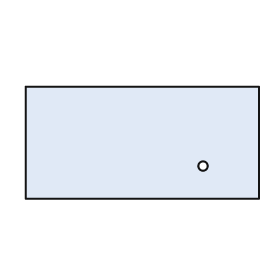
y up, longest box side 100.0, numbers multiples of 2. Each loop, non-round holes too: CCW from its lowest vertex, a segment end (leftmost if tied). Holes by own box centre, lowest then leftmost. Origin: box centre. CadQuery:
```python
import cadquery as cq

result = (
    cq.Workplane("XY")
    .moveTo(-50.0, -24.0)
    .lineTo(50.0, -24.0)
    .lineTo(50.0, 24.0)
    .lineTo(-50.0, 24.0)
    .close()
    .moveTo(26.0, -10.0)
    .circle(2.0)
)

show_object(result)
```